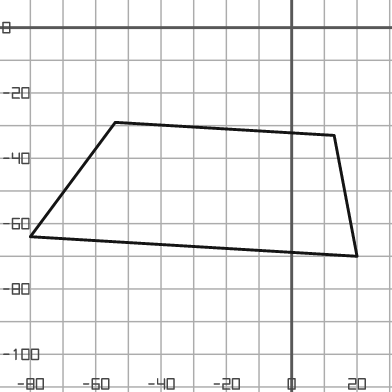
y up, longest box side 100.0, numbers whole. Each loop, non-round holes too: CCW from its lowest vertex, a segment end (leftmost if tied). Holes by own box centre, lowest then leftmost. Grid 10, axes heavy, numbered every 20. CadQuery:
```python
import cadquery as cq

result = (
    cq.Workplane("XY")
    .moveTo(20.0, -70.0)
    .lineTo(13.0, -33.0)
    .lineTo(-54.0, -29.0)
    .lineTo(-80.0, -64.0)
    .close()
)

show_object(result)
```